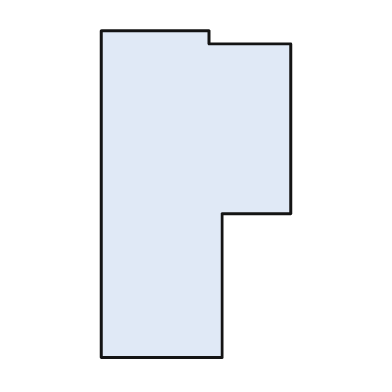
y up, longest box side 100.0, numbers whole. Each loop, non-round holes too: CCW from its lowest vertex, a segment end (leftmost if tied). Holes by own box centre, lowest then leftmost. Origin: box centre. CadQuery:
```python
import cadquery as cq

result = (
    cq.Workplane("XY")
    .moveTo(-29.0, -50.0)
    .lineTo(8.0, -50.0)
    .lineTo(8.0, -6.0)
    .lineTo(29.0, -6.0)
    .lineTo(29.0, 46.0)
    .lineTo(4.0, 46.0)
    .lineTo(4.0, 50.0)
    .lineTo(-29.0, 50.0)
    .close()
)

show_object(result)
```